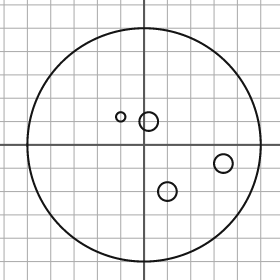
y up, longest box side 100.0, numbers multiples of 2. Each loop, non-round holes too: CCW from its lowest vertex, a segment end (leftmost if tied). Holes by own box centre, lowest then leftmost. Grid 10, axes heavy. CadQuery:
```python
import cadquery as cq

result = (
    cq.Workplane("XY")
    .moveTo(0.0, 0.0)
    .circle(50.0)
    .moveTo(10.0, -20.0)
    .circle(4.0)
    .moveTo(34.0, -8.0)
    .circle(4.0)
    .moveTo(2.0, 10.0)
    .circle(4.0)
    .moveTo(-10.0, 12.0)
    .circle(2.0)
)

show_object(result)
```